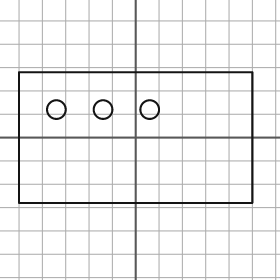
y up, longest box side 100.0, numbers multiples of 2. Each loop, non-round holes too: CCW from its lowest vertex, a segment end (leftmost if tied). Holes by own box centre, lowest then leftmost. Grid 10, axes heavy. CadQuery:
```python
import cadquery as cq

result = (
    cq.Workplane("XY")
    .moveTo(-50.0, -28.0)
    .lineTo(50.0, -28.0)
    .lineTo(50.0, 28.0)
    .lineTo(-50.0, 28.0)
    .close()
    .moveTo(-34.0, 12.0)
    .circle(4.0)
    .moveTo(-14.0, 12.0)
    .circle(4.0)
    .moveTo(6.0, 12.0)
    .circle(4.0)
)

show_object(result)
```